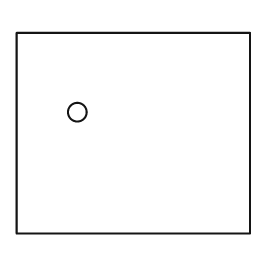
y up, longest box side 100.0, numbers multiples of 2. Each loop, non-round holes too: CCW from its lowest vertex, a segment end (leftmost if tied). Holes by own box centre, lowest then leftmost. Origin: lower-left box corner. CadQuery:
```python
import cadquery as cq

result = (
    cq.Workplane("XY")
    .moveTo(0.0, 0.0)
    .lineTo(100.0, 0.0)
    .lineTo(100.0, 86.0)
    .lineTo(0.0, 86.0)
    .close()
    .moveTo(26.0, 52.0)
    .circle(4.0)
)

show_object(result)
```